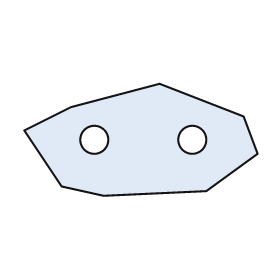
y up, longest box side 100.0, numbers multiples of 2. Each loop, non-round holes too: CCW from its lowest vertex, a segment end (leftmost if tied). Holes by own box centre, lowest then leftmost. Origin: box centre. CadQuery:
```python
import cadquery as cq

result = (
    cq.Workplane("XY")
    .moveTo(-16.0, -24.0)
    .lineTo(28.0, -22.0)
    .lineTo(50.0, -6.0)
    .lineTo(44.0, 10.0)
    .lineTo(8.0, 24.0)
    .lineTo(-30.0, 14.0)
    .lineTo(-50.0, 4.0)
    .lineTo(-34.0, -20.0)
    .close()
    .moveTo(-20.0, 0.0)
    .circle(6.0)
    .moveTo(22.0, 0.0)
    .circle(6.0)
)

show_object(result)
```